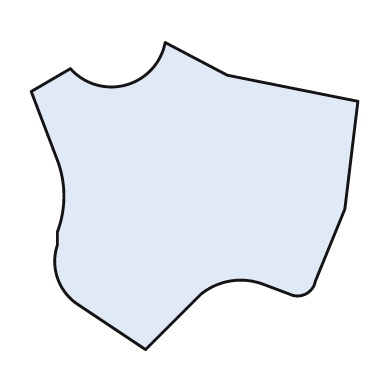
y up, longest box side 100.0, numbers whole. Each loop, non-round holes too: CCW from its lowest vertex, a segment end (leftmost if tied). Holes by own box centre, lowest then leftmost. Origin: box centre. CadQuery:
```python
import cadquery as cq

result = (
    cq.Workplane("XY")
    .moveTo(-15.0, -47.0)
    .lineTo(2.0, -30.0)
    .threePointArc((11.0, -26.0), (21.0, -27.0))
    .lineTo(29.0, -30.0)
    .threePointArc((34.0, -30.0), (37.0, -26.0))
    .lineTo(46.0, -4.0)
    .lineTo(50.0, 29.0)
    .lineTo(10.0, 37.0)
    .lineTo(-9.0, 47.0)
    .threePointArc((-21.0, 34.0), (-38.0, 39.0))
    .lineTo(-50.0, 32.0)
    .lineTo(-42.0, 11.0)
    .threePointArc((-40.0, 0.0), (-42.0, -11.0))
    .lineTo(-42.0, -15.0)
    .threePointArc((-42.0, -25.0), (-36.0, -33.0))
    .close()
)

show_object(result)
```